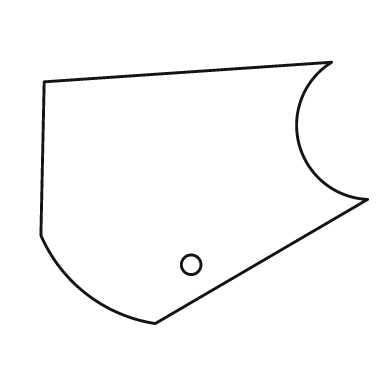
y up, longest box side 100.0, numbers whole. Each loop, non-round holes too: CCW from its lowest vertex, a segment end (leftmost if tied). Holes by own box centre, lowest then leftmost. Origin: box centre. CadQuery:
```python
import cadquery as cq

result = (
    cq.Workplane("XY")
    .moveTo(-15.0, -40.0)
    .lineTo(50.0, -2.0)
    .threePointArc((29.0, 15.0), (39.0, 40.0))
    .lineTo(-49.0, 34.0)
    .lineTo(-50.0, -13.0)
    .threePointArc((-36.0, -31.0), (-15.0, -40.0))
    .close()
    .moveTo(-4.0, -22.0)
    .circle(3.0)
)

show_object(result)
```